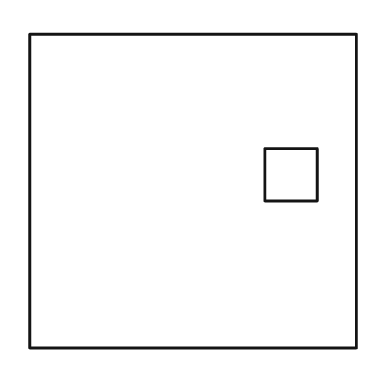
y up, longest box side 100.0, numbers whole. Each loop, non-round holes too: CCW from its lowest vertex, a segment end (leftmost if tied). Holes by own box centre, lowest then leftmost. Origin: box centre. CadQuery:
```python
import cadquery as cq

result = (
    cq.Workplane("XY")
    .moveTo(-50.0, -48.0)
    .lineTo(50.0, -48.0)
    .lineTo(50.0, 48.0)
    .lineTo(-50.0, 48.0)
    .close()
    .moveTo(22.0, -3.0)
    .lineTo(38.0, -3.0)
    .lineTo(38.0, 13.0)
    .lineTo(22.0, 13.0)
    .close()
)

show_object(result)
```